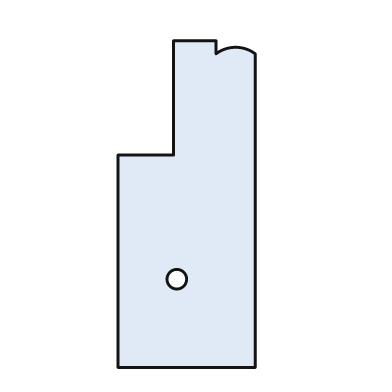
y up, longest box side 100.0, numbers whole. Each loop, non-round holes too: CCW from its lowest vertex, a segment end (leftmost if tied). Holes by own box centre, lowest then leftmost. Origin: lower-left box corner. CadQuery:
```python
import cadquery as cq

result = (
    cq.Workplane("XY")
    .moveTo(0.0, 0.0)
    .lineTo(42.0, 0.0)
    .lineTo(42.0, 96.0)
    .threePointArc((36.0, 98.0), (30.0, 96.0))
    .lineTo(30.0, 100.0)
    .lineTo(17.0, 100.0)
    .lineTo(17.0, 65.0)
    .lineTo(0.0, 65.0)
    .close()
    .moveTo(18.0, 27.0)
    .circle(3.0)
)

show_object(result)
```